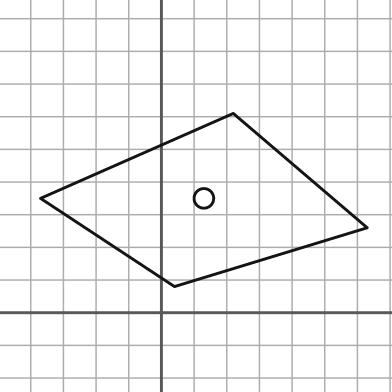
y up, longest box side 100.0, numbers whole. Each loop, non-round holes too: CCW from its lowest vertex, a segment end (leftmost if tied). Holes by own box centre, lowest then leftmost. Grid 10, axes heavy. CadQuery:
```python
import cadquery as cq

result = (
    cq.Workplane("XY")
    .moveTo(4.0, 8.0)
    .lineTo(63.0, 26.0)
    .lineTo(22.0, 61.0)
    .lineTo(-37.0, 35.0)
    .close()
    .moveTo(13.0, 35.0)
    .circle(3.0)
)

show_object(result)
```